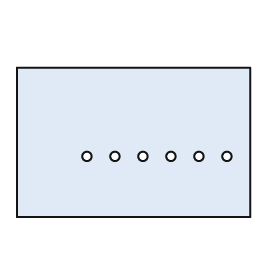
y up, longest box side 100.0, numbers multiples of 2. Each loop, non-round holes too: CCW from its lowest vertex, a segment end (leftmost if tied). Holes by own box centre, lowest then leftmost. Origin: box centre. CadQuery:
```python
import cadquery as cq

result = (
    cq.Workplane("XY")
    .moveTo(-50.0, -32.0)
    .lineTo(50.0, -32.0)
    .lineTo(50.0, 32.0)
    .lineTo(-50.0, 32.0)
    .close()
    .moveTo(-20.0, -6.0)
    .circle(2.0)
    .moveTo(-8.0, -6.0)
    .circle(2.0)
    .moveTo(4.0, -6.0)
    .circle(2.0)
    .moveTo(16.0, -6.0)
    .circle(2.0)
    .moveTo(28.0, -6.0)
    .circle(2.0)
    .moveTo(40.0, -6.0)
    .circle(2.0)
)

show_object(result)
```